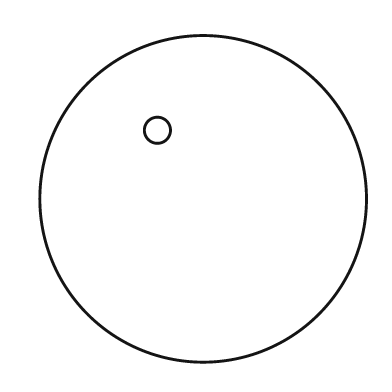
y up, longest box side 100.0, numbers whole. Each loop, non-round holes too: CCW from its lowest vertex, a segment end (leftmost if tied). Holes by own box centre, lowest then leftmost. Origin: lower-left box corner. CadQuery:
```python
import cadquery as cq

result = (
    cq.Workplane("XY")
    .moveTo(50.0, 50.0)
    .circle(50.0)
    .moveTo(36.0, 71.0)
    .circle(4.0)
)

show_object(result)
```